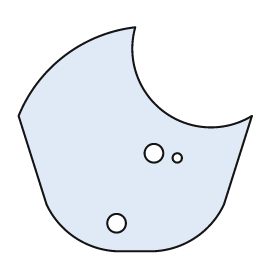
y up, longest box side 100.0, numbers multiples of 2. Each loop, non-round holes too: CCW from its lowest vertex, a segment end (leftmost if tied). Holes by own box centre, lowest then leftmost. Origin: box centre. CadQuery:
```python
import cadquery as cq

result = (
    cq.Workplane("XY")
    .moveTo(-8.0, -48.0)
    .lineTo(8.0, -48.0)
    .threePointArc((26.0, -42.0), (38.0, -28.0))
    .lineTo(50.0, 10.0)
    .threePointArc((12.0, 12.0), (0.0, 48.0))
    .threePointArc((-30.0, 36.0), (-50.0, 10.0))
    .lineTo(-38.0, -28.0)
    .threePointArc((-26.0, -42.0), (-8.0, -48.0))
    .close()
    .moveTo(-8.0, -36.0)
    .circle(4.0)
    .moveTo(18.0, -8.0)
    .circle(2.0)
    .moveTo(8.0, -6.0)
    .circle(4.0)
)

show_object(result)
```